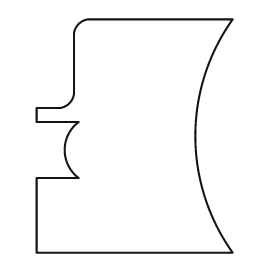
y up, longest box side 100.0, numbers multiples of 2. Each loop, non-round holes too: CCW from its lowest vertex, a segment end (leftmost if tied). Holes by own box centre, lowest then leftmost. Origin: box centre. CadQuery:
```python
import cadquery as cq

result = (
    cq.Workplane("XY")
    .moveTo(-42.0, -50.0)
    .lineTo(42.0, -50.0)
    .threePointArc((26.0, 0.0), (42.0, 50.0))
    .lineTo(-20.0, 50.0)
    .threePointArc((-24.0, 48.0), (-26.0, 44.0))
    .lineTo(-26.0, 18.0)
    .threePointArc((-28.0, 14.0), (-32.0, 12.0))
    .lineTo(-42.0, 12.0)
    .lineTo(-42.0, 6.0)
    .lineTo(-24.0, 6.0)
    .threePointArc((-30.0, -6.0), (-24.0, -18.0))
    .lineTo(-42.0, -18.0)
    .close()
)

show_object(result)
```